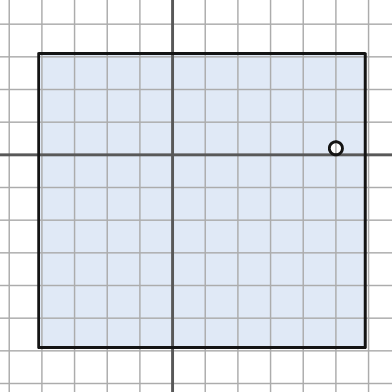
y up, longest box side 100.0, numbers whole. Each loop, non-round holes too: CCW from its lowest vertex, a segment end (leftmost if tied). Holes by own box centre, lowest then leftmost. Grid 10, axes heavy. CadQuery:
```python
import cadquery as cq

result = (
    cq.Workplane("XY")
    .moveTo(-41.0, -59.0)
    .lineTo(59.0, -59.0)
    .lineTo(59.0, 31.0)
    .lineTo(-41.0, 31.0)
    .close()
    .moveTo(50.0, 2.0)
    .circle(2.0)
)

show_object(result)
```